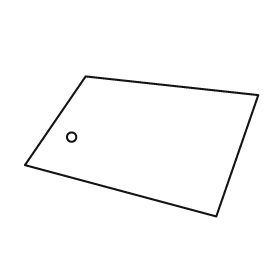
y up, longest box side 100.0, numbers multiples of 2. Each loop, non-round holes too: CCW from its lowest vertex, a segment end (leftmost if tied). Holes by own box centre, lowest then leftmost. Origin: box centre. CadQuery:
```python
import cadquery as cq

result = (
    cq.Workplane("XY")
    .moveTo(32.0, -30.0)
    .lineTo(50.0, 22.0)
    .lineTo(-24.0, 30.0)
    .lineTo(-50.0, -8.0)
    .close()
    .moveTo(-30.0, 4.0)
    .circle(2.0)
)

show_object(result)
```